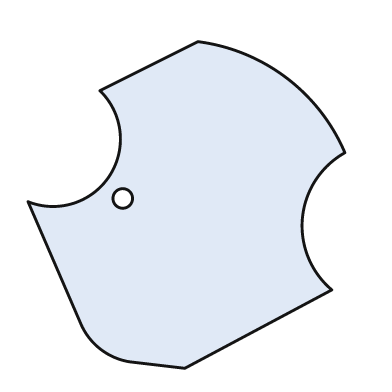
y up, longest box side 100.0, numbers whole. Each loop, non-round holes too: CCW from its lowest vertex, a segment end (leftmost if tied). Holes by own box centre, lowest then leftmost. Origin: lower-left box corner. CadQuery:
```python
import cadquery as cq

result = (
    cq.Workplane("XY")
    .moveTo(48.0, 0.0)
    .lineTo(93.0, 24.0)
    .threePointArc((84.0, 46.0), (97.0, 66.0))
    .threePointArc((79.0, 89.0), (52.0, 100.0))
    .lineTo(22.0, 85.0)
    .threePointArc((25.0, 59.0), (0.0, 51.0))
    .lineTo(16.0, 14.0)
    .threePointArc((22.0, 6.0), (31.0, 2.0))
    .close()
    .moveTo(29.0, 52.0)
    .circle(3.0)
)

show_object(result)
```